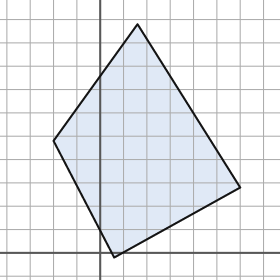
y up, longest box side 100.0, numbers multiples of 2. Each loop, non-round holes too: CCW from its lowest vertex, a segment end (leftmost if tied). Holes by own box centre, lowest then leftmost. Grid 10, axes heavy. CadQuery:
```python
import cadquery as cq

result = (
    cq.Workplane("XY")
    .moveTo(6.0, -2.0)
    .lineTo(60.0, 28.0)
    .lineTo(16.0, 98.0)
    .lineTo(-20.0, 48.0)
    .close()
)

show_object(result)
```